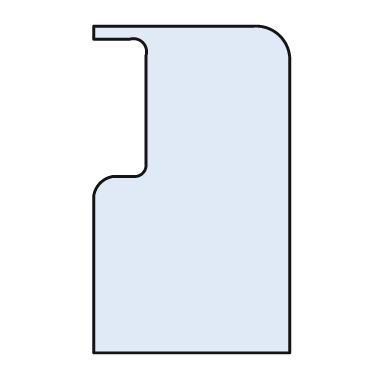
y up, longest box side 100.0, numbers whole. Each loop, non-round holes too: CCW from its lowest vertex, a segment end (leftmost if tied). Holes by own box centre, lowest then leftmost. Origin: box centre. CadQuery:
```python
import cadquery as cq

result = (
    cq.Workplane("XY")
    .moveTo(-30.0, -50.0)
    .lineTo(30.0, -50.0)
    .lineTo(30.0, 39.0)
    .threePointArc((27.0, 47.0), (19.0, 50.0))
    .lineTo(-30.0, 50.0)
    .lineTo(-30.0, 46.0)
    .lineTo(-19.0, 46.0)
    .threePointArc((-15.0, 45.0), (-14.0, 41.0))
    .lineTo(-14.0, 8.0)
    .threePointArc((-15.0, 5.0), (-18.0, 4.0))
    .lineTo(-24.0, 4.0)
    .threePointArc((-28.0, 2.0), (-30.0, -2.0))
    .close()
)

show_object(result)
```